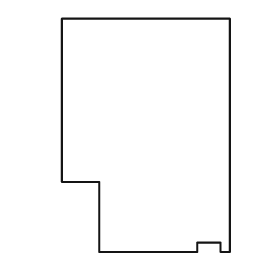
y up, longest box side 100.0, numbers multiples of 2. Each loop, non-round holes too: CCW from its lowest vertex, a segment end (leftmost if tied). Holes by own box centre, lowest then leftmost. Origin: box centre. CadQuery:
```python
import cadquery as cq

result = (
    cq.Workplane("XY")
    .moveTo(-20.0, -50.0)
    .lineTo(22.0, -50.0)
    .lineTo(22.0, -46.0)
    .lineTo(32.0, -46.0)
    .lineTo(32.0, -50.0)
    .lineTo(36.0, -50.0)
    .lineTo(36.0, 50.0)
    .lineTo(-36.0, 50.0)
    .lineTo(-36.0, -20.0)
    .lineTo(-20.0, -20.0)
    .close()
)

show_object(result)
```